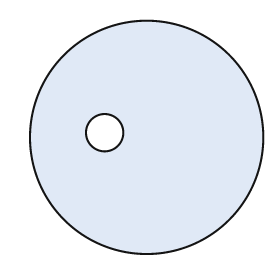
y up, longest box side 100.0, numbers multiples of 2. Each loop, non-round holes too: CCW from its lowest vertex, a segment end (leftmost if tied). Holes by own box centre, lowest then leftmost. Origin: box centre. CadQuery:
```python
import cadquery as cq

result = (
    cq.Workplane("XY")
    .moveTo(0.0, 0.0)
    .circle(50.0)
    .moveTo(-18.0, 2.0)
    .circle(8.0)
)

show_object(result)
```